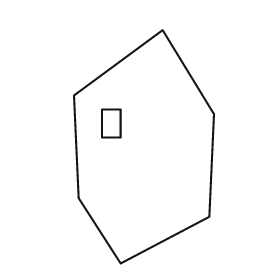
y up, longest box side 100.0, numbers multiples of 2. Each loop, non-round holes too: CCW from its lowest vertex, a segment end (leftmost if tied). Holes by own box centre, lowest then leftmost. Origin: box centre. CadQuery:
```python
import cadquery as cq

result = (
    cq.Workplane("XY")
    .moveTo(-10.0, -50.0)
    .lineTo(28.0, -30.0)
    .lineTo(30.0, 14.0)
    .lineTo(8.0, 50.0)
    .lineTo(-30.0, 22.0)
    .lineTo(-28.0, -22.0)
    .close()
    .moveTo(-18.0, 4.0)
    .lineTo(-10.0, 4.0)
    .lineTo(-10.0, 16.0)
    .lineTo(-18.0, 16.0)
    .close()
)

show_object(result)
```